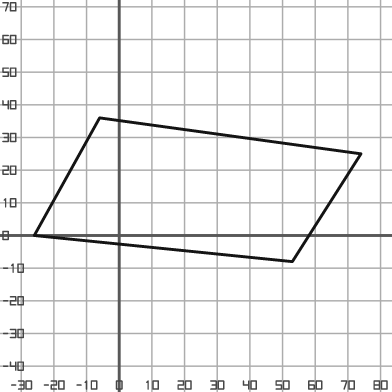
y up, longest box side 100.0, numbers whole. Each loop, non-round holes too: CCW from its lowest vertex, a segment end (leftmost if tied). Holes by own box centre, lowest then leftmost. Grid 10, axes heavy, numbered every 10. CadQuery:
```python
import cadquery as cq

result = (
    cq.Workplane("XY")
    .moveTo(53.0, -8.0)
    .lineTo(74.0, 25.0)
    .lineTo(-6.0, 36.0)
    .lineTo(-26.0, 0.0)
    .close()
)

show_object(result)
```